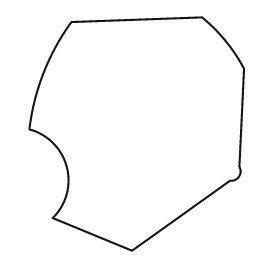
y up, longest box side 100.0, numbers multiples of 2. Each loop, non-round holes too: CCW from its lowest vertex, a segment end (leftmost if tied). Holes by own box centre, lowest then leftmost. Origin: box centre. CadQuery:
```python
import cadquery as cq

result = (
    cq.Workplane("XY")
    .moveTo(-2.0, -50.0)
    .lineTo(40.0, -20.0)
    .threePointArc((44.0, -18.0), (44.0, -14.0))
    .lineTo(46.0, 28.0)
    .threePointArc((38.0, 40.0), (28.0, 50.0))
    .lineTo(-28.0, 48.0)
    .threePointArc((-40.0, 26.0), (-46.0, 2.0))
    .threePointArc((-30.0, -14.0), (-36.0, -36.0))
    .close()
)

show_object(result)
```